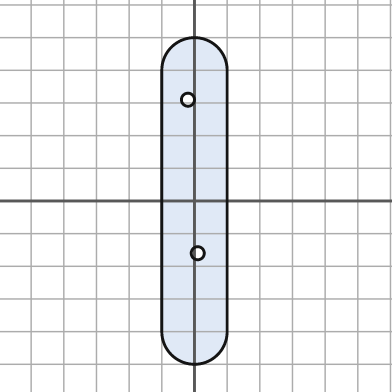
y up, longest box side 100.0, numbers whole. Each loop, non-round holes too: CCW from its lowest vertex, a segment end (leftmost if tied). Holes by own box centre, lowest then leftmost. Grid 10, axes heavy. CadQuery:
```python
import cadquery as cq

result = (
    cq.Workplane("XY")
    .moveTo(-10.0, -40.0)
    .threePointArc((0.0, -50.0), (10.0, -40.0))
    .lineTo(10.0, 40.0)
    .threePointArc((0.0, 50.0), (-10.0, 40.0))
    .close()
    .moveTo(1.0, -16.0)
    .circle(2.0)
    .moveTo(-2.0, 31.0)
    .circle(2.0)
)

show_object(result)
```